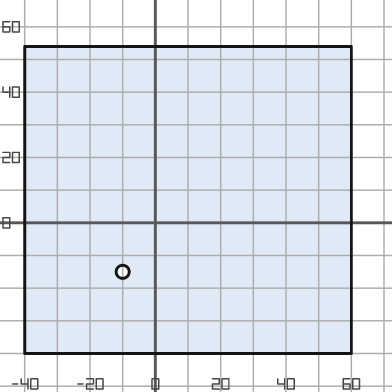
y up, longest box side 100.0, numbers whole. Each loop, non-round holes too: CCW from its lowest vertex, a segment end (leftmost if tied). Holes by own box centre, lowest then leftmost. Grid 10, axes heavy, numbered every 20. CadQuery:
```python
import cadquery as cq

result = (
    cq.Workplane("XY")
    .moveTo(-40.0, -40.0)
    .lineTo(60.0, -40.0)
    .lineTo(60.0, 54.0)
    .lineTo(-40.0, 54.0)
    .close()
    .moveTo(-10.0, -15.0)
    .circle(2.0)
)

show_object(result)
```